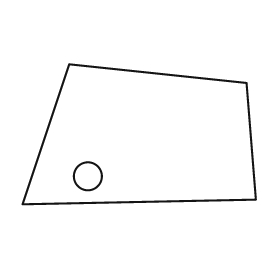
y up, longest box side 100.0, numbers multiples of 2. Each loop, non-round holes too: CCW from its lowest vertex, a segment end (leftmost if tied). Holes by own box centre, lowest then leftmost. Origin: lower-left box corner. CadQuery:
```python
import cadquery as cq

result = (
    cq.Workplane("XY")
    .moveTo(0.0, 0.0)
    .lineTo(100.0, 2.0)
    .lineTo(96.0, 52.0)
    .lineTo(20.0, 60.0)
    .close()
    .moveTo(28.0, 12.0)
    .circle(6.0)
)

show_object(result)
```